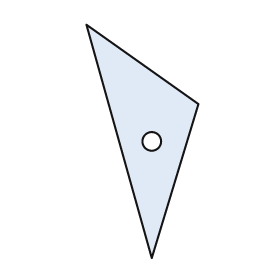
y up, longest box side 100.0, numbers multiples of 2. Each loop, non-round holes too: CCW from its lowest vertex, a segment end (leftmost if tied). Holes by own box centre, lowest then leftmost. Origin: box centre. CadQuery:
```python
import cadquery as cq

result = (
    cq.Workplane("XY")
    .moveTo(4.0, -50.0)
    .lineTo(24.0, 16.0)
    .lineTo(-24.0, 50.0)
    .close()
    .moveTo(4.0, 0.0)
    .circle(4.0)
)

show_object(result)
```